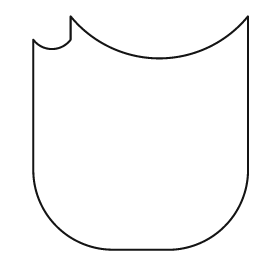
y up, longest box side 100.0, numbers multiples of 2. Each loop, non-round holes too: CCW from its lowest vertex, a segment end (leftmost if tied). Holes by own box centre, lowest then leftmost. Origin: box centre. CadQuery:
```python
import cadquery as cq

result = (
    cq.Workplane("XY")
    .moveTo(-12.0, -50.0)
    .lineTo(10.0, -50.0)
    .threePointArc((36.0, -40.0), (46.0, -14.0))
    .lineTo(46.0, 50.0)
    .threePointArc((8.0, 32.0), (-30.0, 50.0))
    .lineTo(-30.0, 40.0)
    .threePointArc((-38.0, 36.0), (-46.0, 40.0))
    .lineTo(-46.0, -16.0)
    .threePointArc((-36.0, -40.0), (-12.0, -50.0))
    .close()
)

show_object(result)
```